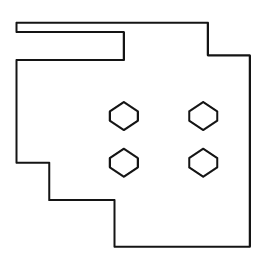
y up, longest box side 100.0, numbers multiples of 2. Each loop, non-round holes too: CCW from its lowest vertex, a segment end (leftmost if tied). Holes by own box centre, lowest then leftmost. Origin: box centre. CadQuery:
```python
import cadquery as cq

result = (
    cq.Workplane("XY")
    .moveTo(-8.0, -48.0)
    .lineTo(50.0, -48.0)
    .lineTo(50.0, 34.0)
    .lineTo(32.0, 34.0)
    .lineTo(32.0, 48.0)
    .lineTo(-50.0, 48.0)
    .lineTo(-50.0, 44.0)
    .lineTo(-4.0, 44.0)
    .lineTo(-4.0, 32.0)
    .lineTo(-50.0, 32.0)
    .lineTo(-50.0, -12.0)
    .lineTo(-36.0, -12.0)
    .lineTo(-36.0, -28.0)
    .lineTo(-8.0, -28.0)
    .close()
    .moveTo(-4.0, -18.0)
    .lineTo(2.0, -14.0)
    .lineTo(2.0, -10.0)
    .lineTo(-4.0, -6.0)
    .lineTo(-10.0, -10.0)
    .lineTo(-10.0, -14.0)
    .close()
    .moveTo(30.0, -18.0)
    .lineTo(36.0, -14.0)
    .lineTo(36.0, -10.0)
    .lineTo(30.0, -6.0)
    .lineTo(24.0, -10.0)
    .lineTo(24.0, -14.0)
    .close()
    .moveTo(-4.0, 2.0)
    .lineTo(2.0, 6.0)
    .lineTo(2.0, 10.0)
    .lineTo(-4.0, 14.0)
    .lineTo(-10.0, 10.0)
    .lineTo(-10.0, 6.0)
    .close()
    .moveTo(30.0, 2.0)
    .lineTo(36.0, 6.0)
    .lineTo(36.0, 10.0)
    .lineTo(30.0, 14.0)
    .lineTo(24.0, 10.0)
    .lineTo(24.0, 6.0)
    .close()
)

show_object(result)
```